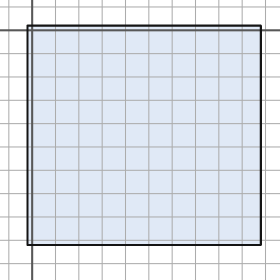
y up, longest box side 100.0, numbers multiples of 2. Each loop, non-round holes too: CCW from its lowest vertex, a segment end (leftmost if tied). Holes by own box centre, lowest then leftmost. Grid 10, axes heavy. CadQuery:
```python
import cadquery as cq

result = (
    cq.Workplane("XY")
    .moveTo(-2.0, -92.0)
    .lineTo(98.0, -92.0)
    .lineTo(98.0, 2.0)
    .lineTo(-2.0, 2.0)
    .close()
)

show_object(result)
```